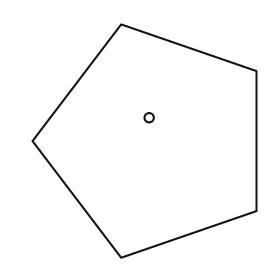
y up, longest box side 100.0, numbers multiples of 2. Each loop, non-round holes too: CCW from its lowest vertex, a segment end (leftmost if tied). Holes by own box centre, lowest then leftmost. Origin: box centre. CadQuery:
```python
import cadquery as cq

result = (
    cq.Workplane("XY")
    .moveTo(-10.0, -50.0)
    .lineTo(48.0, -30.0)
    .lineTo(48.0, 30.0)
    .lineTo(-10.0, 50.0)
    .lineTo(-48.0, 0.0)
    .close()
    .moveTo(2.0, 10.0)
    .circle(2.0)
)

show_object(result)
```